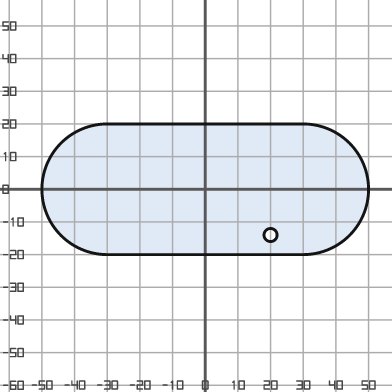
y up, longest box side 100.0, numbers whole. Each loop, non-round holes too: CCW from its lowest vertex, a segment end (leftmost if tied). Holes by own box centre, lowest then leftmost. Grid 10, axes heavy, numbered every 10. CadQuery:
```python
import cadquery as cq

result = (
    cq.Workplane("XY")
    .moveTo(-30.0, -20.0)
    .lineTo(30.0, -20.0)
    .threePointArc((50.0, 0.0), (30.0, 20.0))
    .lineTo(-30.0, 20.0)
    .threePointArc((-50.0, 0.0), (-30.0, -20.0))
    .close()
    .moveTo(20.0, -14.0)
    .circle(2.0)
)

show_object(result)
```